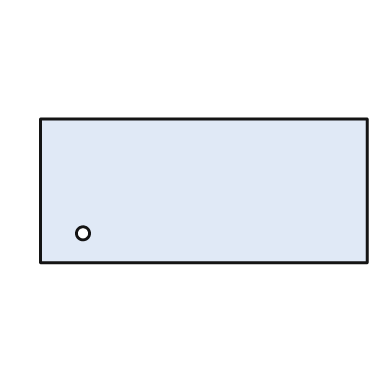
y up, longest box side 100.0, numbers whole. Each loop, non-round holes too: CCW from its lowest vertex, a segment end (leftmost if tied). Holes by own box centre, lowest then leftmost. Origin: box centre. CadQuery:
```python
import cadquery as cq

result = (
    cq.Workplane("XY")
    .moveTo(-50.0, -22.0)
    .lineTo(50.0, -22.0)
    .lineTo(50.0, 22.0)
    .lineTo(-50.0, 22.0)
    .close()
    .moveTo(-37.0, -13.0)
    .circle(2.0)
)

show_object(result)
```